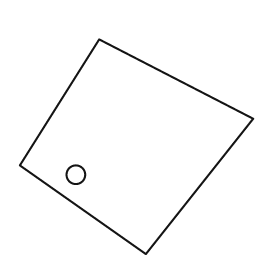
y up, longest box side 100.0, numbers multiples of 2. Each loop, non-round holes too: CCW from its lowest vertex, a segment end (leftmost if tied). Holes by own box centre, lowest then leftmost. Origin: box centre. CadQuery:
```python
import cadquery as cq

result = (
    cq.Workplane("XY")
    .moveTo(4.0, -46.0)
    .lineTo(50.0, 12.0)
    .lineTo(-16.0, 46.0)
    .lineTo(-50.0, -8.0)
    .close()
    .moveTo(-26.0, -12.0)
    .circle(4.0)
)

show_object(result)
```